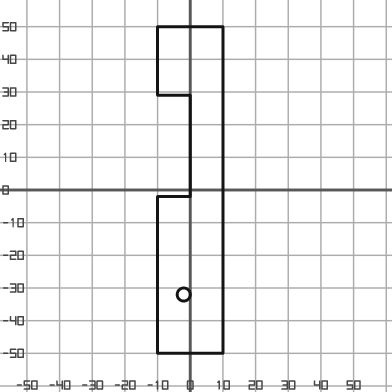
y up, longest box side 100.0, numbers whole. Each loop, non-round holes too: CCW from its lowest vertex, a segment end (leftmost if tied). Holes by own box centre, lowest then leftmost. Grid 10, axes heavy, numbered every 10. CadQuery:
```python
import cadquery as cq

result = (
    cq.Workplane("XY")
    .moveTo(-10.0, -50.0)
    .lineTo(10.0, -50.0)
    .lineTo(10.0, 50.0)
    .lineTo(-10.0, 50.0)
    .lineTo(-10.0, 29.0)
    .lineTo(0.0, 29.0)
    .lineTo(0.0, -2.0)
    .lineTo(-10.0, -2.0)
    .close()
    .moveTo(-2.0, -32.0)
    .circle(2.0)
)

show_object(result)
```